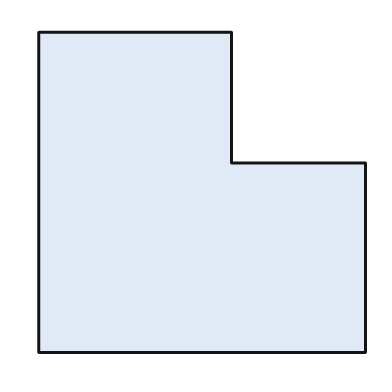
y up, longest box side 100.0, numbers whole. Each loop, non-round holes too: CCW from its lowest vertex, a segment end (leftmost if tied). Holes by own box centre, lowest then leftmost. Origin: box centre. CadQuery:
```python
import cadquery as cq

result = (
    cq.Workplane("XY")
    .moveTo(-50.0, -49.0)
    .lineTo(50.0, -49.0)
    .lineTo(50.0, 9.0)
    .lineTo(9.0, 9.0)
    .lineTo(9.0, 49.0)
    .lineTo(-50.0, 49.0)
    .close()
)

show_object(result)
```